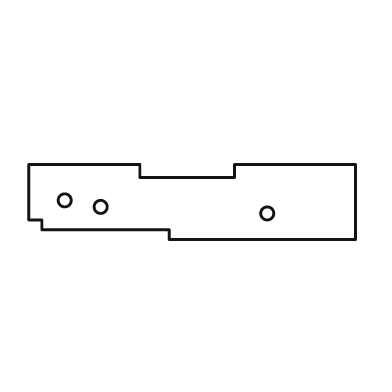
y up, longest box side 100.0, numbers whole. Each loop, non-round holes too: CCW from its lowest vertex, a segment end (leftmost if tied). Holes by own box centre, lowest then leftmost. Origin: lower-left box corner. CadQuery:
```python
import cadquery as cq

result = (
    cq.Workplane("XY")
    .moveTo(43.0, 0.0)
    .lineTo(100.0, 0.0)
    .lineTo(100.0, 23.0)
    .lineTo(63.0, 23.0)
    .lineTo(63.0, 19.0)
    .lineTo(34.0, 19.0)
    .lineTo(34.0, 23.0)
    .lineTo(0.0, 23.0)
    .lineTo(0.0, 6.0)
    .lineTo(4.0, 6.0)
    .lineTo(4.0, 3.0)
    .lineTo(43.0, 3.0)
    .close()
    .moveTo(73.0, 8.0)
    .circle(2.0)
    .moveTo(22.0, 10.0)
    .circle(2.0)
    .moveTo(11.0, 12.0)
    .circle(2.0)
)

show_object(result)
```